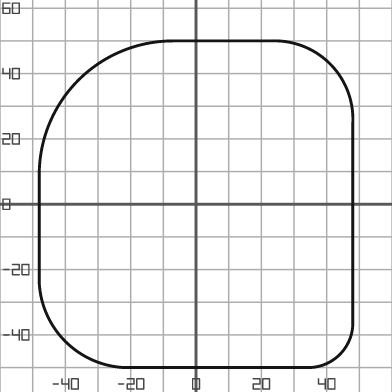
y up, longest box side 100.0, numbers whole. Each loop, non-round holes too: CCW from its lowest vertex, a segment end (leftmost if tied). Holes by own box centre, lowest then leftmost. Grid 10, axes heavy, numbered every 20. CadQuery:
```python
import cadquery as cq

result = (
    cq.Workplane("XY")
    .moveTo(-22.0, -50.0)
    .lineTo(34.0, -50.0)
    .threePointArc((44.0, -46.0), (48.0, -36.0))
    .lineTo(48.0, 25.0)
    .threePointArc((41.0, 43.0), (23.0, 50.0))
    .lineTo(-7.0, 50.0)
    .threePointArc((-36.0, 38.0), (-48.0, 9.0))
    .lineTo(-48.0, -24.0)
    .threePointArc((-40.0, -42.0), (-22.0, -50.0))
    .close()
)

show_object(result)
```